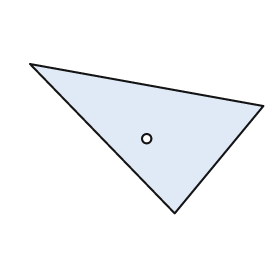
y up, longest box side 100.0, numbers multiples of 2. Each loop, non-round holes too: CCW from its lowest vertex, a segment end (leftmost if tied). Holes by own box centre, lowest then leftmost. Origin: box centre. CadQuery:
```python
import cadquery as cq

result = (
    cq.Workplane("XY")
    .moveTo(12.0, -32.0)
    .lineTo(50.0, 14.0)
    .lineTo(-50.0, 32.0)
    .close()
    .moveTo(0.0, 0.0)
    .circle(2.0)
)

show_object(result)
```